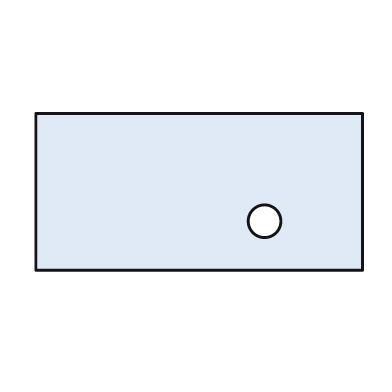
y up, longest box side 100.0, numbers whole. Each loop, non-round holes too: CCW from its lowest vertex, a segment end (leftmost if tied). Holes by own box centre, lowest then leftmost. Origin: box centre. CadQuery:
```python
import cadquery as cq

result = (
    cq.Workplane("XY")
    .moveTo(-50.0, -24.0)
    .lineTo(50.0, -24.0)
    .lineTo(50.0, 24.0)
    .lineTo(-50.0, 24.0)
    .close()
    .moveTo(20.0, -9.0)
    .circle(5.0)
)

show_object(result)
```